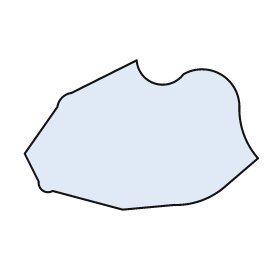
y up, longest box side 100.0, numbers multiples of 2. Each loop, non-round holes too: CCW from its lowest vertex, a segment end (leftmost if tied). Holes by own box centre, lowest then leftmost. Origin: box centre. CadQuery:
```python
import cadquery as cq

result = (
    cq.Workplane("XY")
    .moveTo(-8.0, -32.0)
    .lineTo(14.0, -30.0)
    .threePointArc((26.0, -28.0), (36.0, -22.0))
    .lineTo(50.0, -10.0)
    .threePointArc((44.0, 0.0), (42.0, 12.0))
    .threePointArc((34.0, 26.0), (18.0, 26.0))
    .threePointArc((6.0, 22.0), (-2.0, 32.0))
    .lineTo(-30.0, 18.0)
    .threePointArc((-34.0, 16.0), (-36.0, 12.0))
    .lineTo(-50.0, -8.0)
    .lineTo(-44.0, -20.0)
    .threePointArc((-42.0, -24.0), (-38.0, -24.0))
    .close()
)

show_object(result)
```